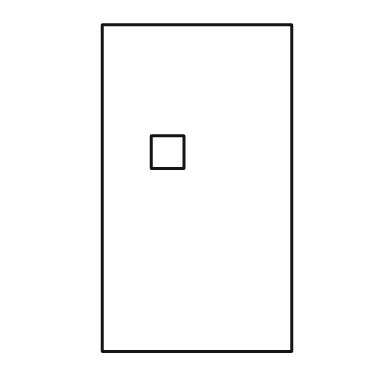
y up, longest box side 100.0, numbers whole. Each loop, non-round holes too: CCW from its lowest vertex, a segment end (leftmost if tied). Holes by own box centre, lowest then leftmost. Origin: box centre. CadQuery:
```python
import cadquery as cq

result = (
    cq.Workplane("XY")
    .moveTo(-29.0, -50.0)
    .lineTo(29.0, -50.0)
    .lineTo(29.0, 50.0)
    .lineTo(-29.0, 50.0)
    .close()
    .moveTo(-14.0, 6.0)
    .lineTo(-4.0, 6.0)
    .lineTo(-4.0, 16.0)
    .lineTo(-14.0, 16.0)
    .close()
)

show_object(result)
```